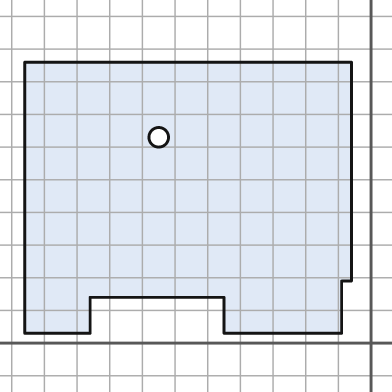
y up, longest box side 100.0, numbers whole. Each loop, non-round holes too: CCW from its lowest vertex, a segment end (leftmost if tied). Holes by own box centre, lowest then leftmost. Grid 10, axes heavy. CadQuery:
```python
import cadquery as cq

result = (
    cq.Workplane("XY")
    .moveTo(-106.0, 3.0)
    .lineTo(-86.0, 3.0)
    .lineTo(-86.0, 14.0)
    .lineTo(-45.0, 14.0)
    .lineTo(-45.0, 3.0)
    .lineTo(-9.0, 3.0)
    .lineTo(-9.0, 19.0)
    .lineTo(-6.0, 19.0)
    .lineTo(-6.0, 86.0)
    .lineTo(-106.0, 86.0)
    .close()
    .moveTo(-65.0, 63.0)
    .circle(3.0)
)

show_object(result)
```